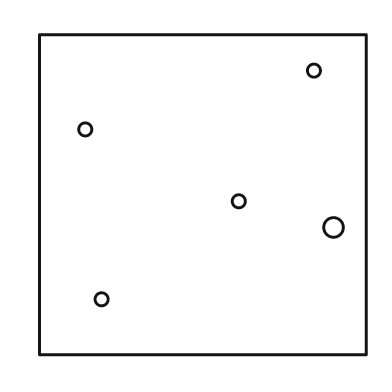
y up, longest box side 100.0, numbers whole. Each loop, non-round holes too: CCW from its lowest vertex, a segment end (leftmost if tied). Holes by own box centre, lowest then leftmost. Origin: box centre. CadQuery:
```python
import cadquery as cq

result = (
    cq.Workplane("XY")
    .moveTo(-50.0, -49.0)
    .lineTo(50.0, -49.0)
    .lineTo(50.0, 49.0)
    .lineTo(-50.0, 49.0)
    .close()
    .moveTo(-31.0, -32.0)
    .circle(2.0)
    .moveTo(40.0, -10.0)
    .circle(3.0)
    .moveTo(11.0, -2.0)
    .circle(2.0)
    .moveTo(-36.0, 20.0)
    .circle(2.0)
    .moveTo(34.0, 38.0)
    .circle(2.0)
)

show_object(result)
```